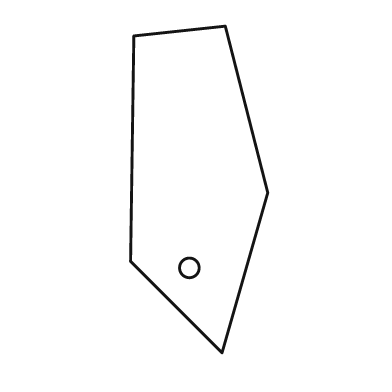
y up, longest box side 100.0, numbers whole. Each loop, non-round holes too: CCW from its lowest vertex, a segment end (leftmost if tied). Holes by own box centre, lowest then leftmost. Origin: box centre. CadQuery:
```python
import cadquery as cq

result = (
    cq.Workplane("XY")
    .moveTo(7.0, -50.0)
    .lineTo(21.0, -1.0)
    .lineTo(8.0, 50.0)
    .lineTo(-20.0, 47.0)
    .lineTo(-21.0, -22.0)
    .close()
    .moveTo(-3.0, -24.0)
    .circle(3.0)
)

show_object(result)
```